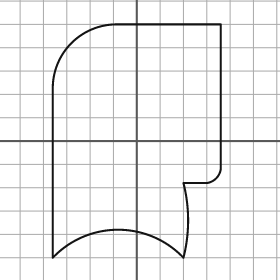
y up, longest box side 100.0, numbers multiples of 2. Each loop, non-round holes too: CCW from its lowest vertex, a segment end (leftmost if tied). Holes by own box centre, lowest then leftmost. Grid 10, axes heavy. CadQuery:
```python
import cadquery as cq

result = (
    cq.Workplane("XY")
    .moveTo(-36.0, -50.0)
    .threePointArc((-8.0, -38.0), (20.0, -50.0))
    .threePointArc((22.0, -34.0), (20.0, -18.0))
    .lineTo(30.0, -18.0)
    .threePointArc((34.0, -16.0), (36.0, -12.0))
    .lineTo(36.0, 50.0)
    .lineTo(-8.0, 50.0)
    .threePointArc((-28.0, 42.0), (-36.0, 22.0))
    .close()
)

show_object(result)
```